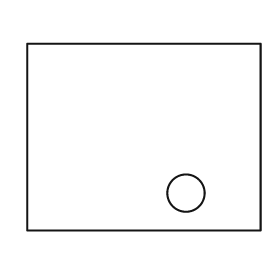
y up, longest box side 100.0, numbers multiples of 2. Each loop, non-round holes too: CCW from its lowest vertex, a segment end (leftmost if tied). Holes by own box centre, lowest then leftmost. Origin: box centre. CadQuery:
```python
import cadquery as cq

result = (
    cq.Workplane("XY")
    .moveTo(-50.0, -40.0)
    .lineTo(50.0, -40.0)
    .lineTo(50.0, 40.0)
    .lineTo(-50.0, 40.0)
    .close()
    .moveTo(18.0, -24.0)
    .circle(8.0)
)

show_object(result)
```